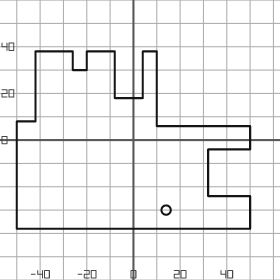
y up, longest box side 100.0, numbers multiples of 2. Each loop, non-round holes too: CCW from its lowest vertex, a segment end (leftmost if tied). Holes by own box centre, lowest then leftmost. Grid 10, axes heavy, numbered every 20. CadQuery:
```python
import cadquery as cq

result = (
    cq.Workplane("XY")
    .moveTo(-50.0, -38.0)
    .lineTo(50.0, -38.0)
    .lineTo(50.0, -24.0)
    .lineTo(32.0, -24.0)
    .lineTo(32.0, -4.0)
    .lineTo(50.0, -4.0)
    .lineTo(50.0, 6.0)
    .lineTo(10.0, 6.0)
    .lineTo(10.0, 38.0)
    .lineTo(4.0, 38.0)
    .lineTo(4.0, 18.0)
    .lineTo(-8.0, 18.0)
    .lineTo(-8.0, 38.0)
    .lineTo(-20.0, 38.0)
    .lineTo(-20.0, 30.0)
    .lineTo(-26.0, 30.0)
    .lineTo(-26.0, 38.0)
    .lineTo(-42.0, 38.0)
    .lineTo(-42.0, 8.0)
    .lineTo(-50.0, 8.0)
    .close()
    .moveTo(14.0, -30.0)
    .circle(2.0)
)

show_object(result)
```